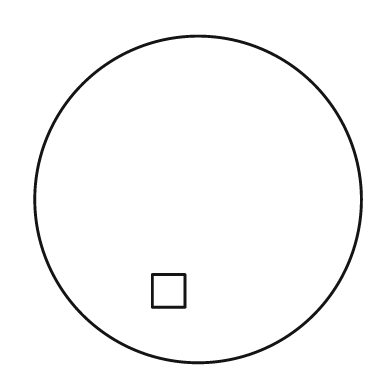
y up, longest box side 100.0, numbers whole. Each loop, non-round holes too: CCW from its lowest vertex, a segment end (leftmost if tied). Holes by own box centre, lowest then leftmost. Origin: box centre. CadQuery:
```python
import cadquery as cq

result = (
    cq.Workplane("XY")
    .moveTo(0.0, 0.0)
    .circle(50.0)
    .moveTo(-14.0, -33.0)
    .lineTo(-4.0, -33.0)
    .lineTo(-4.0, -23.0)
    .lineTo(-14.0, -23.0)
    .close()
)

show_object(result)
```